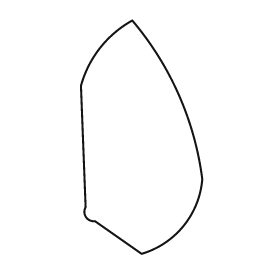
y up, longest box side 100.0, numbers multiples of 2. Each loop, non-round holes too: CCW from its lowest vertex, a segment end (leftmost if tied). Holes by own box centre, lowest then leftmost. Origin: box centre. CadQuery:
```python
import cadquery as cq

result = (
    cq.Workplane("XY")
    .moveTo(0.0, -50.0)
    .threePointArc((18.0, -38.0), (26.0, -18.0))
    .threePointArc((16.0, 18.0), (-4.0, 50.0))
    .threePointArc((-18.0, 38.0), (-26.0, 22.0))
    .lineTo(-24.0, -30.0)
    .threePointArc((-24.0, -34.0), (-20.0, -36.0))
    .close()
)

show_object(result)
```